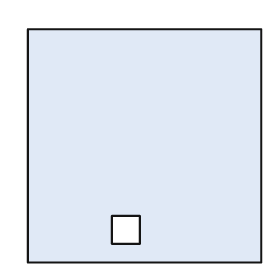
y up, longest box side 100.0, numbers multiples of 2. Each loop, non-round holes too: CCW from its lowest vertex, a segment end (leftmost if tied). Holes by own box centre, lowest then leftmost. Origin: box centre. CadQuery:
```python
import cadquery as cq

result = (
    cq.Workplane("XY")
    .moveTo(-50.0, -50.0)
    .lineTo(50.0, -50.0)
    .lineTo(50.0, 50.0)
    .lineTo(-50.0, 50.0)
    .close()
    .moveTo(-14.0, -42.0)
    .lineTo(-2.0, -42.0)
    .lineTo(-2.0, -30.0)
    .lineTo(-14.0, -30.0)
    .close()
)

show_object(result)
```